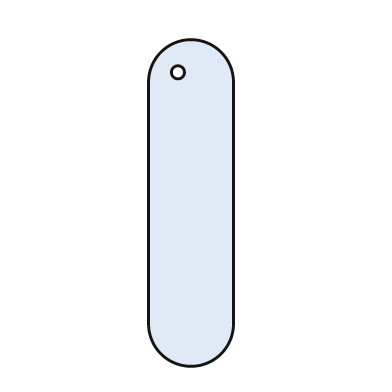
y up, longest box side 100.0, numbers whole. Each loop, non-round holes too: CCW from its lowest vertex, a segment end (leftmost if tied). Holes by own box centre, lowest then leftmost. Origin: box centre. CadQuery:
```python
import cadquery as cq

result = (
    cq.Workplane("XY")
    .moveTo(-13.0, -37.0)
    .threePointArc((0.0, -50.0), (13.0, -37.0))
    .lineTo(13.0, 37.0)
    .threePointArc((0.0, 50.0), (-13.0, 37.0))
    .close()
    .moveTo(-4.0, 40.0)
    .circle(2.0)
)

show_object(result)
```